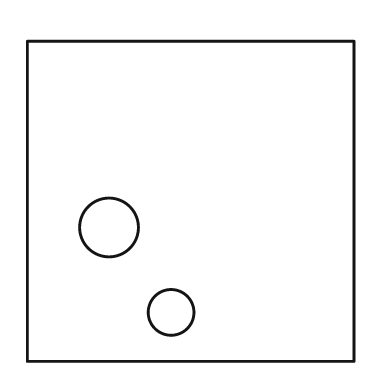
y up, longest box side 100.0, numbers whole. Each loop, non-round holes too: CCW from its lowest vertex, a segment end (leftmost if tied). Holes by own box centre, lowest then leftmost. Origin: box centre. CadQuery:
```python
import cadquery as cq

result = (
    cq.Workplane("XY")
    .moveTo(-50.0, -49.0)
    .lineTo(50.0, -49.0)
    .lineTo(50.0, 49.0)
    .lineTo(-50.0, 49.0)
    .close()
    .moveTo(-6.0, -34.0)
    .circle(7.0)
    .moveTo(-25.0, -8.0)
    .circle(9.0)
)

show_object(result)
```